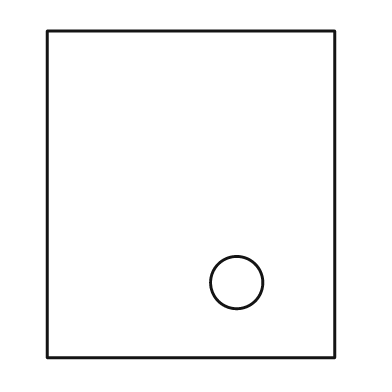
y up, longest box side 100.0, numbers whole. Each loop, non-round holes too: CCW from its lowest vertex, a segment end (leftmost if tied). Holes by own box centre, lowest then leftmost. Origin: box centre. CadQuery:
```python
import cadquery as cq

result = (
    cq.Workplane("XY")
    .moveTo(-44.0, -50.0)
    .lineTo(44.0, -50.0)
    .lineTo(44.0, 50.0)
    .lineTo(-44.0, 50.0)
    .close()
    .moveTo(14.0, -27.0)
    .circle(8.0)
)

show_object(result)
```